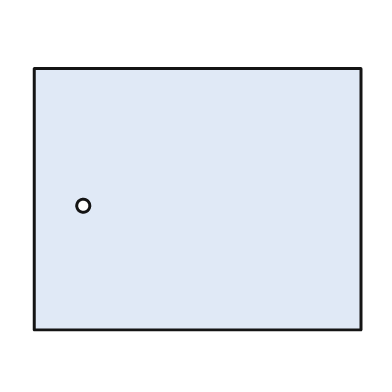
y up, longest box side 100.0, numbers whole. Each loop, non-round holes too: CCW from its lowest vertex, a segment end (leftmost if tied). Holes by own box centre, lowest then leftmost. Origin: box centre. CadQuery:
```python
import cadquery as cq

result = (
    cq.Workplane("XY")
    .moveTo(-50.0, -40.0)
    .lineTo(50.0, -40.0)
    .lineTo(50.0, 40.0)
    .lineTo(-50.0, 40.0)
    .close()
    .moveTo(-35.0, -2.0)
    .circle(2.0)
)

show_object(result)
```